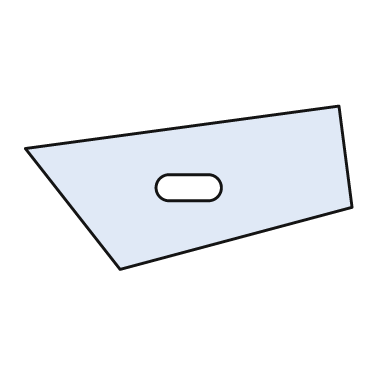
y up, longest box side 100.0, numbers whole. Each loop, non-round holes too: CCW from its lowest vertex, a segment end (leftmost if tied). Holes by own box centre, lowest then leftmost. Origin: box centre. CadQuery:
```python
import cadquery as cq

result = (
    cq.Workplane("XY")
    .moveTo(-21.0, -25.0)
    .lineTo(50.0, -6.0)
    .lineTo(46.0, 25.0)
    .lineTo(-50.0, 12.0)
    .close()
    .moveTo(-6.0, -4.0)
    .lineTo(6.0, -4.0)
    .threePointArc((10.0, 0.0), (6.0, 4.0))
    .lineTo(-6.0, 4.0)
    .threePointArc((-10.0, 0.0), (-6.0, -4.0))
    .close()
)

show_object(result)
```